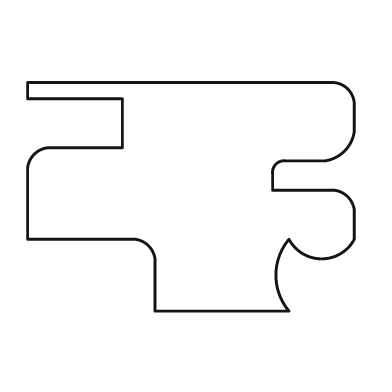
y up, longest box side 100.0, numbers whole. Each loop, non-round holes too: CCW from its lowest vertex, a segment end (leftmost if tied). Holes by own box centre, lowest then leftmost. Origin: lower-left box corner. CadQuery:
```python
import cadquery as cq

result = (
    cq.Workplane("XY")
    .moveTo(39.0, 0.0)
    .lineTo(80.0, 0.0)
    .threePointArc((76.0, 11.0), (80.0, 22.0))
    .threePointArc((90.0, 16.0), (100.0, 22.0))
    .lineTo(100.0, 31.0)
    .threePointArc((98.0, 35.0), (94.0, 37.0))
    .lineTo(75.0, 37.0)
    .lineTo(75.0, 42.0)
    .threePointArc((76.0, 45.0), (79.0, 46.0))
    .lineTo(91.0, 46.0)
    .threePointArc((97.0, 49.0), (100.0, 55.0))
    .lineTo(100.0, 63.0)
    .threePointArc((98.0, 68.0), (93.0, 70.0))
    .lineTo(0.0, 70.0)
    .lineTo(0.0, 65.0)
    .lineTo(29.0, 65.0)
    .lineTo(29.0, 50.0)
    .lineTo(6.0, 50.0)
    .threePointArc((2.0, 48.0), (0.0, 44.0))
    .lineTo(0.0, 22.0)
    .lineTo(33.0, 22.0)
    .threePointArc((37.0, 20.0), (39.0, 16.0))
    .close()
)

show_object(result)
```